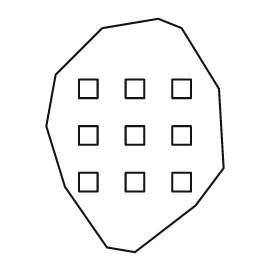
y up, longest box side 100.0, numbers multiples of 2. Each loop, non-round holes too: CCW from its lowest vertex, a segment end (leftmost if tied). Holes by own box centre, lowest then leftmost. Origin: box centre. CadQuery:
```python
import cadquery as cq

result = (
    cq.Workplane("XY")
    .moveTo(0.0, -50.0)
    .lineTo(26.0, -30.0)
    .lineTo(38.0, -14.0)
    .lineTo(36.0, 20.0)
    .lineTo(20.0, 46.0)
    .lineTo(10.0, 50.0)
    .lineTo(-14.0, 46.0)
    .lineTo(-34.0, 26.0)
    .lineTo(-38.0, 4.0)
    .lineTo(-30.0, -22.0)
    .lineTo(-12.0, -48.0)
    .close()
    .moveTo(-24.0, -24.0)
    .lineTo(-16.0, -24.0)
    .lineTo(-16.0, -16.0)
    .lineTo(-24.0, -16.0)
    .close()
    .moveTo(-4.0, -24.0)
    .lineTo(4.0, -24.0)
    .lineTo(4.0, -16.0)
    .lineTo(-4.0, -16.0)
    .close()
    .moveTo(16.0, -24.0)
    .lineTo(24.0, -24.0)
    .lineTo(24.0, -16.0)
    .lineTo(16.0, -16.0)
    .close()
    .moveTo(-24.0, -4.0)
    .lineTo(-16.0, -4.0)
    .lineTo(-16.0, 4.0)
    .lineTo(-24.0, 4.0)
    .close()
    .moveTo(-4.0, -4.0)
    .lineTo(4.0, -4.0)
    .lineTo(4.0, 4.0)
    .lineTo(-4.0, 4.0)
    .close()
    .moveTo(16.0, -4.0)
    .lineTo(24.0, -4.0)
    .lineTo(24.0, 4.0)
    .lineTo(16.0, 4.0)
    .close()
    .moveTo(-24.0, 16.0)
    .lineTo(-16.0, 16.0)
    .lineTo(-16.0, 24.0)
    .lineTo(-24.0, 24.0)
    .close()
    .moveTo(-4.0, 16.0)
    .lineTo(4.0, 16.0)
    .lineTo(4.0, 24.0)
    .lineTo(-4.0, 24.0)
    .close()
    .moveTo(16.0, 16.0)
    .lineTo(24.0, 16.0)
    .lineTo(24.0, 24.0)
    .lineTo(16.0, 24.0)
    .close()
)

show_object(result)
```